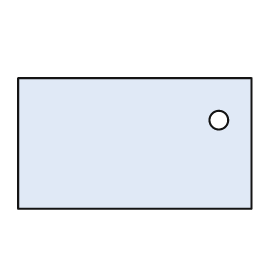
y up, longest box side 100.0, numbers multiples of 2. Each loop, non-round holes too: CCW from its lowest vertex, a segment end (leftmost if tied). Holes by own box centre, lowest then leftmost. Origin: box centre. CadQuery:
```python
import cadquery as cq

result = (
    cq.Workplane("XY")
    .moveTo(-50.0, -28.0)
    .lineTo(50.0, -28.0)
    .lineTo(50.0, 28.0)
    .lineTo(-50.0, 28.0)
    .close()
    .moveTo(36.0, 10.0)
    .circle(4.0)
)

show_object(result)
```